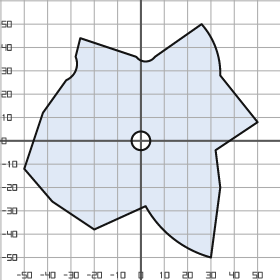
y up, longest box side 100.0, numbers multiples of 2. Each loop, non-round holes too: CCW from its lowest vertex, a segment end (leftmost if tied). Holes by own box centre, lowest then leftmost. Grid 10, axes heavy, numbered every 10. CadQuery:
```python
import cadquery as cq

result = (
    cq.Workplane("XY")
    .moveTo(30.0, -50.0)
    .lineTo(34.0, -20.0)
    .lineTo(32.0, -4.0)
    .lineTo(50.0, 8.0)
    .lineTo(34.0, 28.0)
    .threePointArc((32.0, 40.0), (26.0, 50.0))
    .lineTo(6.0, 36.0)
    .threePointArc((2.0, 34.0), (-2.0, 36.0))
    .lineTo(-26.0, 44.0)
    .lineTo(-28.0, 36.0)
    .threePointArc((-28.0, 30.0), (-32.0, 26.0))
    .lineTo(-42.0, 12.0)
    .lineTo(-50.0, -12.0)
    .lineTo(-38.0, -26.0)
    .lineTo(-20.0, -38.0)
    .lineTo(2.0, -28.0)
    .threePointArc((14.0, -42.0), (30.0, -50.0))
    .close()
    .moveTo(0.0, 0.0)
    .circle(4.0)
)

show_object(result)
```